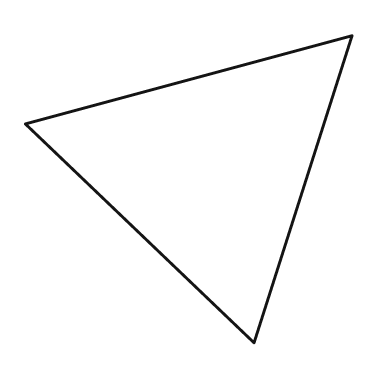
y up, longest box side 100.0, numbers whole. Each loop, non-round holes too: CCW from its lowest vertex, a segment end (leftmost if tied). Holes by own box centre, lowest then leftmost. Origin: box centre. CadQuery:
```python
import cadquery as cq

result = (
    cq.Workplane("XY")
    .moveTo(20.0, -47.0)
    .lineTo(50.0, 47.0)
    .lineTo(-50.0, 20.0)
    .close()
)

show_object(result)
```